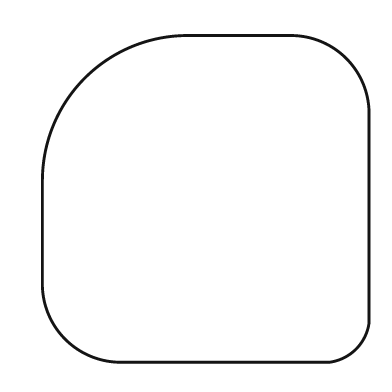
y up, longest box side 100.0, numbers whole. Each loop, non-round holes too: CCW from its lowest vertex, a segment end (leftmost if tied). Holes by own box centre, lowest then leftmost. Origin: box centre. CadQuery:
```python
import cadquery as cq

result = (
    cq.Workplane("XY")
    .moveTo(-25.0, -50.0)
    .lineTo(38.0, -50.0)
    .threePointArc((46.0, -46.0), (50.0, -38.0))
    .lineTo(50.0, 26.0)
    .threePointArc((43.0, 43.0), (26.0, 50.0))
    .lineTo(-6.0, 50.0)
    .threePointArc((-37.0, 37.0), (-50.0, 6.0))
    .lineTo(-50.0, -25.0)
    .threePointArc((-43.0, -43.0), (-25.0, -50.0))
    .close()
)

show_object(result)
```